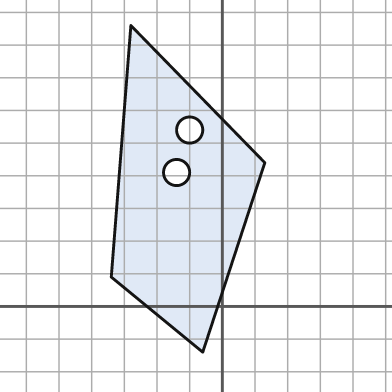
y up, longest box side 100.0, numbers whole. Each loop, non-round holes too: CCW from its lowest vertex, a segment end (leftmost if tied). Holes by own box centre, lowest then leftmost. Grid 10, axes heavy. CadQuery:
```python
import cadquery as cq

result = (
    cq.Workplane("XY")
    .moveTo(-6.0, -14.0)
    .lineTo(13.0, 44.0)
    .lineTo(-28.0, 86.0)
    .lineTo(-34.0, 9.0)
    .close()
    .moveTo(-14.0, 41.0)
    .circle(4.0)
    .moveTo(-10.0, 54.0)
    .circle(4.0)
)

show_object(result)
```